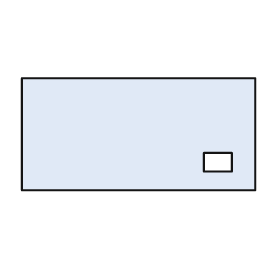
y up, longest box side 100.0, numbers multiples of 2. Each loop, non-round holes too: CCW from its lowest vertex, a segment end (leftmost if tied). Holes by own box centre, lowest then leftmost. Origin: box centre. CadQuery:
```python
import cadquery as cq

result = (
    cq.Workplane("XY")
    .moveTo(-50.0, -24.0)
    .lineTo(50.0, -24.0)
    .lineTo(50.0, 24.0)
    .lineTo(-50.0, 24.0)
    .close()
    .moveTo(28.0, -16.0)
    .lineTo(40.0, -16.0)
    .lineTo(40.0, -8.0)
    .lineTo(28.0, -8.0)
    .close()
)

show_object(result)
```